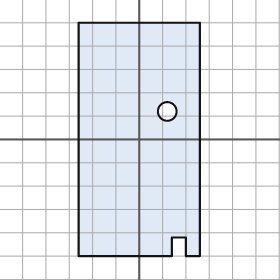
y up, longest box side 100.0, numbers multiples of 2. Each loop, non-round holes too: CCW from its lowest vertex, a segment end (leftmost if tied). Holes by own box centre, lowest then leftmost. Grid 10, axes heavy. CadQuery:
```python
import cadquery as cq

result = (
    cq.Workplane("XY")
    .moveTo(-26.0, -50.0)
    .lineTo(14.0, -50.0)
    .lineTo(14.0, -42.0)
    .lineTo(20.0, -42.0)
    .lineTo(20.0, -50.0)
    .lineTo(26.0, -50.0)
    .lineTo(26.0, 50.0)
    .lineTo(-26.0, 50.0)
    .close()
    .moveTo(12.0, 12.0)
    .circle(4.0)
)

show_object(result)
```